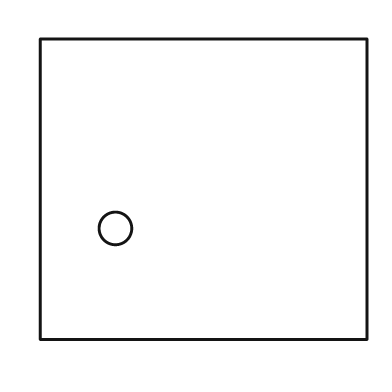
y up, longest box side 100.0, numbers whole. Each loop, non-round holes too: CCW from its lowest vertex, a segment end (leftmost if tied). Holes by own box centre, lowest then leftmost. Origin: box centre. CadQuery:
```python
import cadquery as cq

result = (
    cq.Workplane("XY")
    .moveTo(-50.0, -46.0)
    .lineTo(50.0, -46.0)
    .lineTo(50.0, 46.0)
    .lineTo(-50.0, 46.0)
    .close()
    .moveTo(-27.0, -12.0)
    .circle(5.0)
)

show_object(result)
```